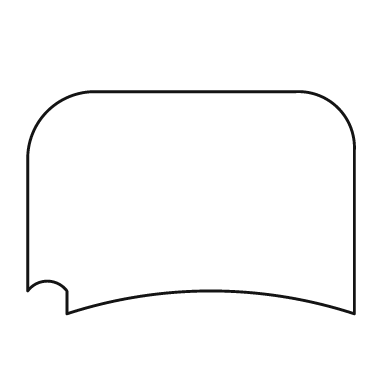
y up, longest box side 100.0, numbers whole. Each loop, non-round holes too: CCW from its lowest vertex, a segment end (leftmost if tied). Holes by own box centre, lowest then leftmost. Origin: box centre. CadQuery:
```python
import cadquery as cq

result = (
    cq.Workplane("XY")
    .moveTo(-38.0, -34.0)
    .threePointArc((6.0, -27.0), (50.0, -34.0))
    .lineTo(50.0, 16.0)
    .threePointArc((45.0, 29.0), (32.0, 34.0))
    .lineTo(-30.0, 34.0)
    .threePointArc((-44.0, 28.0), (-50.0, 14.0))
    .lineTo(-50.0, -27.0)
    .threePointArc((-44.0, -24.0), (-38.0, -27.0))
    .close()
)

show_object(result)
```